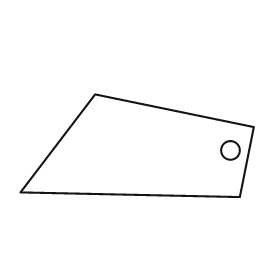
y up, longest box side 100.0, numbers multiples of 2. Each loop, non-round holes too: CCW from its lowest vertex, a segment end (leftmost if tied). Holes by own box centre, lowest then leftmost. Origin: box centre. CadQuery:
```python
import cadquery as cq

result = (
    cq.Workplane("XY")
    .moveTo(44.0, -22.0)
    .lineTo(50.0, 8.0)
    .lineTo(-18.0, 22.0)
    .lineTo(-50.0, -20.0)
    .close()
    .moveTo(40.0, -2.0)
    .circle(4.0)
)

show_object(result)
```